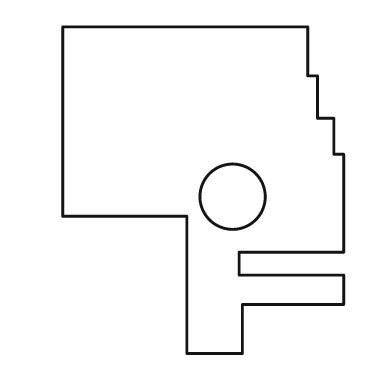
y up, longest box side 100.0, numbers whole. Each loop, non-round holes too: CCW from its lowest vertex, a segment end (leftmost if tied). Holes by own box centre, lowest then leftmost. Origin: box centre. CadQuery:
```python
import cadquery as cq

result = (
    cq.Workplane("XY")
    .moveTo(-5.0, -50.0)
    .lineTo(12.0, -50.0)
    .lineTo(12.0, -35.0)
    .lineTo(43.0, -35.0)
    .lineTo(43.0, -26.0)
    .lineTo(11.0, -26.0)
    .lineTo(11.0, -19.0)
    .lineTo(43.0, -19.0)
    .lineTo(43.0, 11.0)
    .lineTo(40.0, 11.0)
    .lineTo(40.0, 22.0)
    .lineTo(35.0, 22.0)
    .lineTo(35.0, 35.0)
    .lineTo(32.0, 35.0)
    .lineTo(32.0, 50.0)
    .lineTo(-43.0, 50.0)
    .lineTo(-43.0, -8.0)
    .lineTo(-5.0, -8.0)
    .close()
    .moveTo(9.0, -2.0)
    .circle(10.0)
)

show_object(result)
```